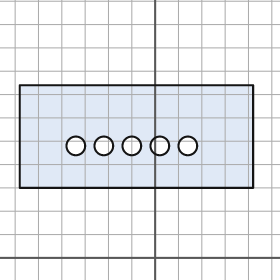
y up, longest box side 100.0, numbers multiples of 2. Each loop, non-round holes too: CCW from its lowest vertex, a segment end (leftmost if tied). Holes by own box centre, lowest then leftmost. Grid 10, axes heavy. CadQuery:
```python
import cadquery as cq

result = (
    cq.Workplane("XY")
    .moveTo(-58.0, 30.0)
    .lineTo(42.0, 30.0)
    .lineTo(42.0, 74.0)
    .lineTo(-58.0, 74.0)
    .close()
    .moveTo(-34.0, 48.0)
    .circle(4.0)
    .moveTo(-22.0, 48.0)
    .circle(4.0)
    .moveTo(-10.0, 48.0)
    .circle(4.0)
    .moveTo(2.0, 48.0)
    .circle(4.0)
    .moveTo(14.0, 48.0)
    .circle(4.0)
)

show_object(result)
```